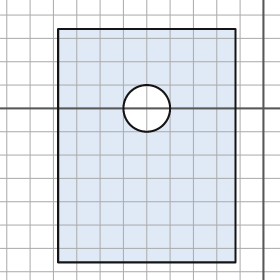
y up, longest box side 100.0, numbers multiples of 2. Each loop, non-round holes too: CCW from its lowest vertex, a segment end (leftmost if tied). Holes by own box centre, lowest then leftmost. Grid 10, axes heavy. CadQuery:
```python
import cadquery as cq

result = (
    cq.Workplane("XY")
    .moveTo(-88.0, -66.0)
    .lineTo(-12.0, -66.0)
    .lineTo(-12.0, 34.0)
    .lineTo(-88.0, 34.0)
    .close()
    .moveTo(-50.0, 0.0)
    .circle(10.0)
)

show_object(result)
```